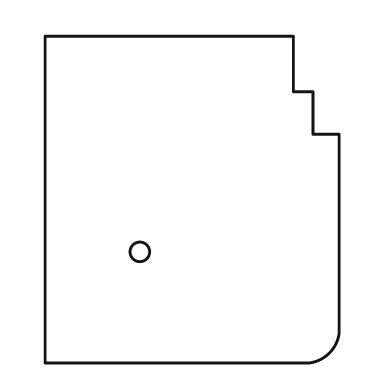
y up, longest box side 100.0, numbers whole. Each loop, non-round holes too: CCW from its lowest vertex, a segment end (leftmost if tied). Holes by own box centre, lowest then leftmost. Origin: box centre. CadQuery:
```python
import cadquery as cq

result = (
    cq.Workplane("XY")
    .moveTo(-45.0, -50.0)
    .lineTo(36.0, -50.0)
    .threePointArc((42.0, -47.0), (45.0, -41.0))
    .lineTo(45.0, 20.0)
    .lineTo(37.0, 20.0)
    .lineTo(37.0, 33.0)
    .lineTo(31.0, 33.0)
    .lineTo(31.0, 50.0)
    .lineTo(-45.0, 50.0)
    .close()
    .moveTo(-16.0, -16.0)
    .circle(3.0)
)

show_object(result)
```